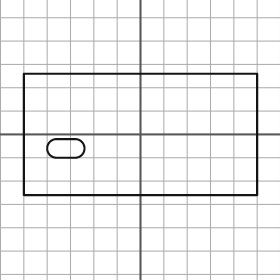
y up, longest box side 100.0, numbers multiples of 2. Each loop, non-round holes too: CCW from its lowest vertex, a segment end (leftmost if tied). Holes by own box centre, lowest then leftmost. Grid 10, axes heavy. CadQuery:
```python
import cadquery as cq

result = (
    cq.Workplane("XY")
    .moveTo(-50.0, -26.0)
    .lineTo(50.0, -26.0)
    .lineTo(50.0, 26.0)
    .lineTo(-50.0, 26.0)
    .close()
    .moveTo(-36.0, -10.0)
    .lineTo(-28.0, -10.0)
    .threePointArc((-24.0, -6.0), (-28.0, -2.0))
    .lineTo(-36.0, -2.0)
    .threePointArc((-40.0, -6.0), (-36.0, -10.0))
    .close()
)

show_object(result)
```